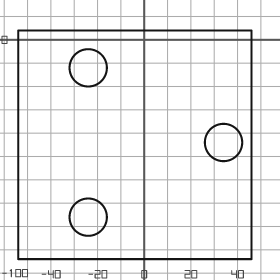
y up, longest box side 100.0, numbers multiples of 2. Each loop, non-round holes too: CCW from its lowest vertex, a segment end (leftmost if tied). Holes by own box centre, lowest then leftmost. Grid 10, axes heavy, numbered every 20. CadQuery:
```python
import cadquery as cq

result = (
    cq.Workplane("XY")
    .moveTo(-54.0, -94.0)
    .lineTo(46.0, -94.0)
    .lineTo(46.0, 4.0)
    .lineTo(-54.0, 4.0)
    .close()
    .moveTo(-24.0, -76.0)
    .circle(8.0)
    .moveTo(34.0, -44.0)
    .circle(8.0)
    .moveTo(-24.0, -12.0)
    .circle(8.0)
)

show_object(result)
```